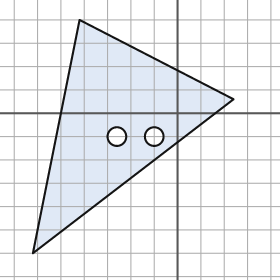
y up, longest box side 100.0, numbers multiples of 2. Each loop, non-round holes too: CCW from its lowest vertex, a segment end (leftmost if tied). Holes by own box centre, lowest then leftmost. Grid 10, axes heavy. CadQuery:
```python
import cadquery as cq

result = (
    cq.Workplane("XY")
    .moveTo(-62.0, -60.0)
    .lineTo(24.0, 6.0)
    .lineTo(-42.0, 40.0)
    .close()
    .moveTo(-26.0, -10.0)
    .circle(4.0)
    .moveTo(-10.0, -10.0)
    .circle(4.0)
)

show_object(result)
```